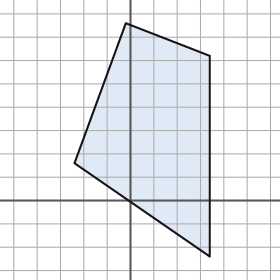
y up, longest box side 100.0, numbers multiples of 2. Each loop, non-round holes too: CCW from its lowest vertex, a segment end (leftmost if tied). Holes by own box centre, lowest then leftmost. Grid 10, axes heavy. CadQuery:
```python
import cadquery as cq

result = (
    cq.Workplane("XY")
    .moveTo(34.0, -24.0)
    .lineTo(34.0, 62.0)
    .lineTo(-2.0, 76.0)
    .lineTo(-24.0, 16.0)
    .close()
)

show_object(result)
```